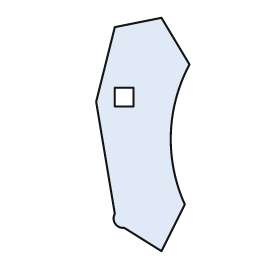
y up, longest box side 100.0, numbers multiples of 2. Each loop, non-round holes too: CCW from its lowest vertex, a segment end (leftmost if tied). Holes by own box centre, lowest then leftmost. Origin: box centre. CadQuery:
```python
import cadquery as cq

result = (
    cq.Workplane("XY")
    .moveTo(8.0, -50.0)
    .lineTo(18.0, -30.0)
    .threePointArc((12.0, 0.0), (20.0, 30.0))
    .lineTo(8.0, 50.0)
    .lineTo(-12.0, 46.0)
    .lineTo(-20.0, 14.0)
    .lineTo(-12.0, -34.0)
    .threePointArc((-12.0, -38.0), (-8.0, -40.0))
    .close()
    .moveTo(-12.0, 12.0)
    .lineTo(-4.0, 12.0)
    .lineTo(-4.0, 20.0)
    .lineTo(-12.0, 20.0)
    .close()
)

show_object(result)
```